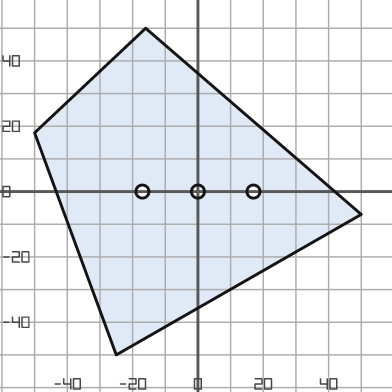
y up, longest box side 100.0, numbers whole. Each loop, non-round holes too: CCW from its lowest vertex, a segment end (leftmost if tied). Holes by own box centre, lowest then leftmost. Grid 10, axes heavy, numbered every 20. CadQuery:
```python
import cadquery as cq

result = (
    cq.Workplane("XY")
    .moveTo(-25.0, -50.0)
    .lineTo(50.0, -7.0)
    .lineTo(-16.0, 50.0)
    .lineTo(-50.0, 18.0)
    .close()
    .moveTo(-17.0, 0.0)
    .circle(2.0)
    .moveTo(0.0, 0.0)
    .circle(2.0)
    .moveTo(17.0, 0.0)
    .circle(2.0)
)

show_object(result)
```